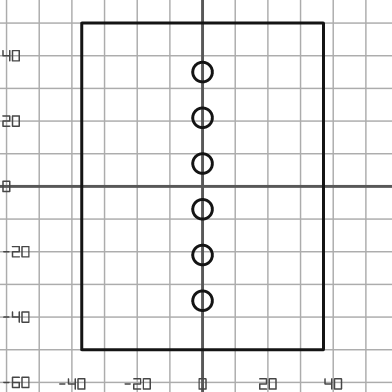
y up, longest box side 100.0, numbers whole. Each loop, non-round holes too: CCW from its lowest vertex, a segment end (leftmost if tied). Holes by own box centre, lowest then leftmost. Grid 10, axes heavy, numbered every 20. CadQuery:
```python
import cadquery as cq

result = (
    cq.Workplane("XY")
    .moveTo(-37.0, -50.0)
    .lineTo(37.0, -50.0)
    .lineTo(37.0, 50.0)
    .lineTo(-37.0, 50.0)
    .close()
    .moveTo(0.0, -35.0)
    .circle(3.0)
    .moveTo(0.0, -21.0)
    .circle(3.0)
    .moveTo(0.0, -7.0)
    .circle(3.0)
    .moveTo(0.0, 7.0)
    .circle(3.0)
    .moveTo(0.0, 21.0)
    .circle(3.0)
    .moveTo(0.0, 35.0)
    .circle(3.0)
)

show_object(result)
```